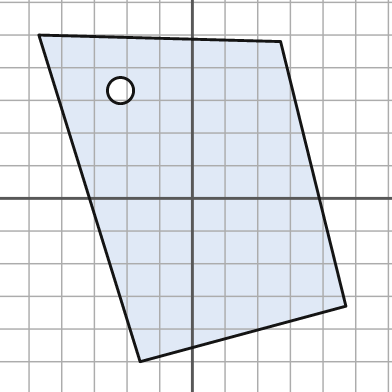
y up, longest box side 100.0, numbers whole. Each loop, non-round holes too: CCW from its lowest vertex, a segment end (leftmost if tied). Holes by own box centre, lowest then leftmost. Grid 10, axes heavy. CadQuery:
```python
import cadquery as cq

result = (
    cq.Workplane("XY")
    .moveTo(-16.0, -50.0)
    .lineTo(47.0, -33.0)
    .lineTo(27.0, 48.0)
    .lineTo(-47.0, 50.0)
    .close()
    .moveTo(-22.0, 33.0)
    .circle(4.0)
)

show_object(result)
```